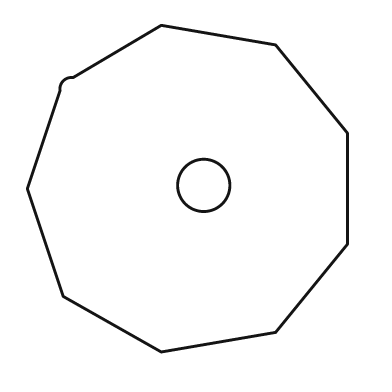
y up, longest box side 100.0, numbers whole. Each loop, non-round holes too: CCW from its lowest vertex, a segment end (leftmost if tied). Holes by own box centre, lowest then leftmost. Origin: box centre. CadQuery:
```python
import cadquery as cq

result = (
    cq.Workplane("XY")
    .moveTo(-8.0, -50.0)
    .lineTo(27.0, -44.0)
    .lineTo(49.0, -17.0)
    .lineTo(49.0, 17.0)
    .lineTo(27.0, 44.0)
    .lineTo(-8.0, 50.0)
    .lineTo(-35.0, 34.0)
    .threePointArc((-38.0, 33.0), (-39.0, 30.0))
    .lineTo(-49.0, 0.0)
    .lineTo(-38.0, -33.0)
    .close()
    .moveTo(5.0, 1.0)
    .circle(8.0)
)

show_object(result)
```